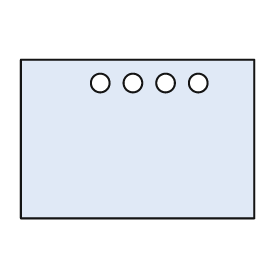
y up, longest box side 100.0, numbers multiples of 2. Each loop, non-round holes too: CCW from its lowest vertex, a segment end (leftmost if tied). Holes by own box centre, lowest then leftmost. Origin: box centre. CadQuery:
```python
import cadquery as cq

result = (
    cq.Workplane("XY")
    .moveTo(-50.0, -34.0)
    .lineTo(50.0, -34.0)
    .lineTo(50.0, 34.0)
    .lineTo(-50.0, 34.0)
    .close()
    .moveTo(-16.0, 24.0)
    .circle(4.0)
    .moveTo(-2.0, 24.0)
    .circle(4.0)
    .moveTo(12.0, 24.0)
    .circle(4.0)
    .moveTo(26.0, 24.0)
    .circle(4.0)
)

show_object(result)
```